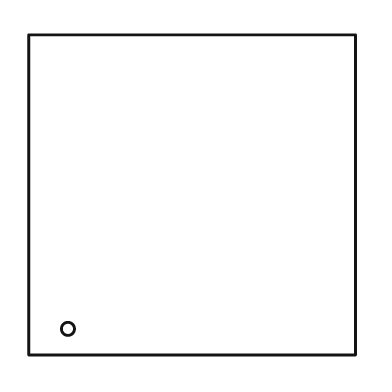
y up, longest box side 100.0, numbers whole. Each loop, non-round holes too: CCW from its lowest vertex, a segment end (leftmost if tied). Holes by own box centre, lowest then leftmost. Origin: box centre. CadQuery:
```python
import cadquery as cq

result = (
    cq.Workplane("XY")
    .moveTo(-50.0, -49.0)
    .lineTo(50.0, -49.0)
    .lineTo(50.0, 49.0)
    .lineTo(-50.0, 49.0)
    .close()
    .moveTo(-38.0, -41.0)
    .circle(2.0)
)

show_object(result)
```